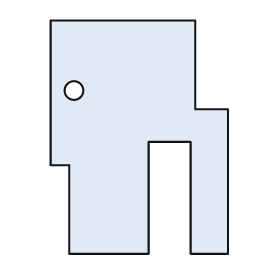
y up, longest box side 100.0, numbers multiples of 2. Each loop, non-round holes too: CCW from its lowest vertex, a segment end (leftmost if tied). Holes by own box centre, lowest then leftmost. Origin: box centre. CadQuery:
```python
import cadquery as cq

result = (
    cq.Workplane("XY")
    .moveTo(-30.0, -50.0)
    .lineTo(4.0, -50.0)
    .lineTo(4.0, -2.0)
    .lineTo(22.0, -2.0)
    .lineTo(22.0, -50.0)
    .lineTo(38.0, -50.0)
    .lineTo(38.0, 12.0)
    .lineTo(24.0, 12.0)
    .lineTo(24.0, 50.0)
    .lineTo(-38.0, 50.0)
    .lineTo(-38.0, -12.0)
    .lineTo(-30.0, -12.0)
    .close()
    .moveTo(-28.0, 20.0)
    .circle(4.0)
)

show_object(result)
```